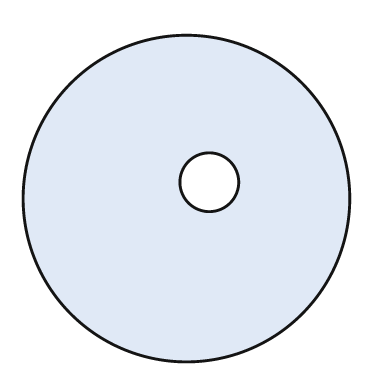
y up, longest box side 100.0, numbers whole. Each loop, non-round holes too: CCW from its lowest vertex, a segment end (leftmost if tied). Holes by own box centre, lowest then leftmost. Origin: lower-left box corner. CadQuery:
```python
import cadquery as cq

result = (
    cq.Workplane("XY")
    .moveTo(50.0, 50.0)
    .circle(50.0)
    .moveTo(57.0, 55.0)
    .circle(9.0)
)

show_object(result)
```